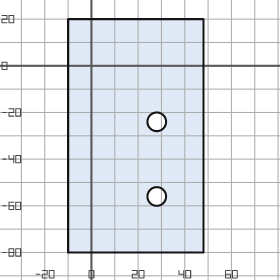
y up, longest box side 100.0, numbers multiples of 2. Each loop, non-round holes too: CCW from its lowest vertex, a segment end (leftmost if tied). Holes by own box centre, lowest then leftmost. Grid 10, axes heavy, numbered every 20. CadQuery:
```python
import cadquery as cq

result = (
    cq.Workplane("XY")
    .moveTo(-10.0, -80.0)
    .lineTo(48.0, -80.0)
    .lineTo(48.0, 20.0)
    .lineTo(-10.0, 20.0)
    .close()
    .moveTo(28.0, -56.0)
    .circle(4.0)
    .moveTo(28.0, -24.0)
    .circle(4.0)
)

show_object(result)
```